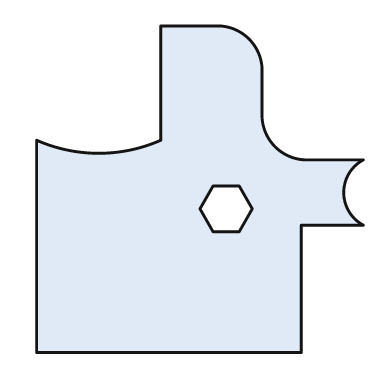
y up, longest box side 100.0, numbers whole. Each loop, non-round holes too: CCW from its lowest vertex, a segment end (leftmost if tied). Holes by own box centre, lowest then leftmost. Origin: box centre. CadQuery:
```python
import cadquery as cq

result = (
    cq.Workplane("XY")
    .moveTo(-50.0, -50.0)
    .lineTo(31.0, -50.0)
    .lineTo(31.0, -11.0)
    .lineTo(50.0, -11.0)
    .threePointArc((44.0, -1.0), (50.0, 9.0))
    .lineTo(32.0, 9.0)
    .threePointArc((23.0, 13.0), (19.0, 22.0))
    .lineTo(19.0, 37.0)
    .threePointArc((15.0, 46.0), (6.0, 50.0))
    .lineTo(-12.0, 50.0)
    .lineTo(-12.0, 15.0)
    .threePointArc((-31.0, 11.0), (-50.0, 15.0))
    .close()
    .moveTo(4.0, -13.0)
    .lineTo(12.0, -13.0)
    .lineTo(16.0, -6.0)
    .lineTo(12.0, 1.0)
    .lineTo(4.0, 1.0)
    .lineTo(0.0, -6.0)
    .close()
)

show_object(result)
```